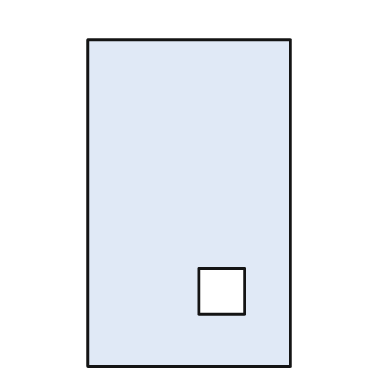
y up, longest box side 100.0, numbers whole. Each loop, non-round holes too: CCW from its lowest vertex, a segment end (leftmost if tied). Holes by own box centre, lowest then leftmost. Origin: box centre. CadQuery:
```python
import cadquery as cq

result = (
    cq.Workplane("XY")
    .moveTo(-31.0, -50.0)
    .lineTo(31.0, -50.0)
    .lineTo(31.0, 50.0)
    .lineTo(-31.0, 50.0)
    .close()
    .moveTo(3.0, -34.0)
    .lineTo(17.0, -34.0)
    .lineTo(17.0, -20.0)
    .lineTo(3.0, -20.0)
    .close()
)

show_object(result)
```